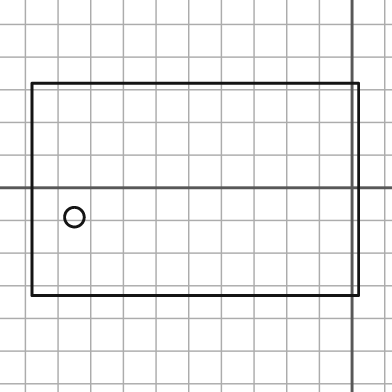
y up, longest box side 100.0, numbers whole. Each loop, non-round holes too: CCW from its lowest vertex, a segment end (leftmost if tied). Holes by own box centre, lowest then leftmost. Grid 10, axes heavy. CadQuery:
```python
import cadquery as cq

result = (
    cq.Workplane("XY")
    .moveTo(-98.0, -33.0)
    .lineTo(2.0, -33.0)
    .lineTo(2.0, 32.0)
    .lineTo(-98.0, 32.0)
    .close()
    .moveTo(-85.0, -9.0)
    .circle(3.0)
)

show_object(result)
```